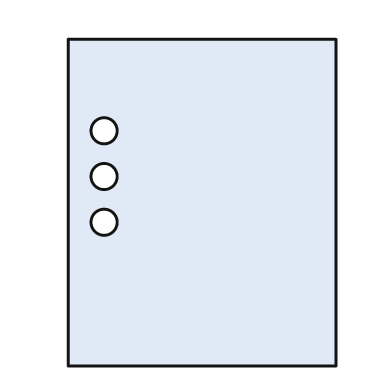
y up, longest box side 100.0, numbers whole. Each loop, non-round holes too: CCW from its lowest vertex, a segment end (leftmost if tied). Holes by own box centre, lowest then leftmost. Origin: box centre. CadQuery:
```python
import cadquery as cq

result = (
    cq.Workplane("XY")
    .moveTo(-41.0, -50.0)
    .lineTo(41.0, -50.0)
    .lineTo(41.0, 50.0)
    .lineTo(-41.0, 50.0)
    .close()
    .moveTo(-30.0, -6.0)
    .circle(4.0)
    .moveTo(-30.0, 8.0)
    .circle(4.0)
    .moveTo(-30.0, 22.0)
    .circle(4.0)
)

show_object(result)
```